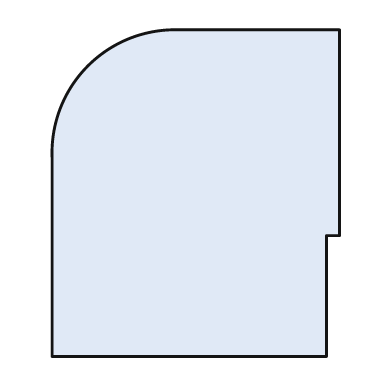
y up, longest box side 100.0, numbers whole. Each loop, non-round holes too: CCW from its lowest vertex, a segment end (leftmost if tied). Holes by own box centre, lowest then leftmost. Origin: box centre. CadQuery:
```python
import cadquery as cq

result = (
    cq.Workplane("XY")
    .moveTo(-44.0, -50.0)
    .lineTo(40.0, -50.0)
    .lineTo(40.0, -13.0)
    .lineTo(44.0, -13.0)
    .lineTo(44.0, 50.0)
    .lineTo(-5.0, 50.0)
    .threePointArc((-33.0, 39.0), (-44.0, 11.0))
    .close()
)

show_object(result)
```